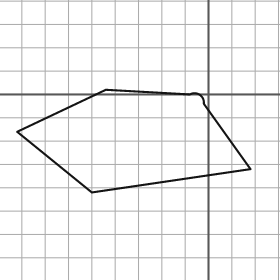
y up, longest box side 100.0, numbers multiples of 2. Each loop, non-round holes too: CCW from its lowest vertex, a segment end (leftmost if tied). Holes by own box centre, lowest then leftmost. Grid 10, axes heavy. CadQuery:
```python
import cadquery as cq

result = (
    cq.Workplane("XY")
    .moveTo(-50.0, -42.0)
    .lineTo(18.0, -32.0)
    .lineTo(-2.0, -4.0)
    .threePointArc((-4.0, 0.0), (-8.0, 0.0))
    .lineTo(-44.0, 2.0)
    .lineTo(-82.0, -16.0)
    .close()
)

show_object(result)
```